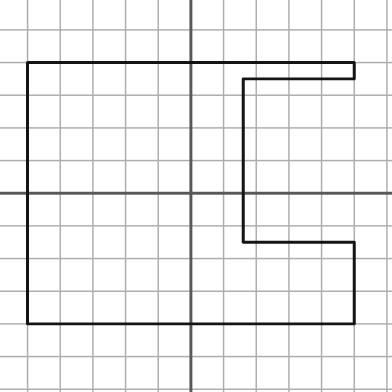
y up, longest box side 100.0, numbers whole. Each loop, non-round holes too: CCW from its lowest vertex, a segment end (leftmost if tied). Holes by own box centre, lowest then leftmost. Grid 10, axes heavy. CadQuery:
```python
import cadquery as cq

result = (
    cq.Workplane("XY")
    .moveTo(-50.0, -40.0)
    .lineTo(50.0, -40.0)
    .lineTo(50.0, -15.0)
    .lineTo(16.0, -15.0)
    .lineTo(16.0, 35.0)
    .lineTo(50.0, 35.0)
    .lineTo(50.0, 40.0)
    .lineTo(-50.0, 40.0)
    .close()
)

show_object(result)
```